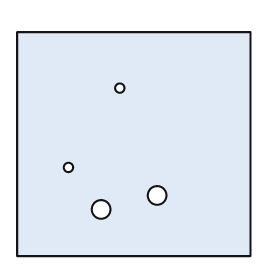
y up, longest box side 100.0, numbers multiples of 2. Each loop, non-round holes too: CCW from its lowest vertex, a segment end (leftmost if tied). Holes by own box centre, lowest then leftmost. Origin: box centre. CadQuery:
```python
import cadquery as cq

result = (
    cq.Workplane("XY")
    .moveTo(-50.0, -48.0)
    .lineTo(50.0, -48.0)
    .lineTo(50.0, 48.0)
    .lineTo(-50.0, 48.0)
    .close()
    .moveTo(-14.0, -28.0)
    .circle(4.0)
    .moveTo(10.0, -22.0)
    .circle(4.0)
    .moveTo(-28.0, -10.0)
    .circle(2.0)
    .moveTo(-6.0, 24.0)
    .circle(2.0)
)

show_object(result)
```